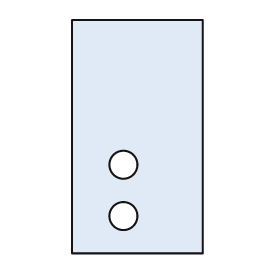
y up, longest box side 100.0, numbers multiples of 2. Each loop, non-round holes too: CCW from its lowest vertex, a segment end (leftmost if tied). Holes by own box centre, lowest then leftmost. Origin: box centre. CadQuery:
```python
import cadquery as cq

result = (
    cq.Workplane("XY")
    .moveTo(-28.0, -50.0)
    .lineTo(28.0, -50.0)
    .lineTo(28.0, 50.0)
    .lineTo(-28.0, 50.0)
    .close()
    .moveTo(-6.0, -34.0)
    .circle(6.0)
    .moveTo(-6.0, -12.0)
    .circle(6.0)
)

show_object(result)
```